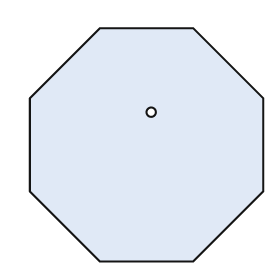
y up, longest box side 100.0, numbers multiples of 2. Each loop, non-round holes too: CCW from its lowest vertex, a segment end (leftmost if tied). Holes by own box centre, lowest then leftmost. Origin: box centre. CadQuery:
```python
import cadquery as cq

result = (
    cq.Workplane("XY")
    .moveTo(-20.0, -50.0)
    .lineTo(20.0, -50.0)
    .lineTo(50.0, -20.0)
    .lineTo(50.0, 20.0)
    .lineTo(20.0, 50.0)
    .lineTo(-20.0, 50.0)
    .lineTo(-50.0, 20.0)
    .lineTo(-50.0, -20.0)
    .close()
    .moveTo(2.0, 14.0)
    .circle(2.0)
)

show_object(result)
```